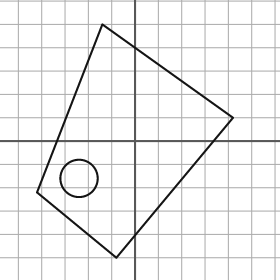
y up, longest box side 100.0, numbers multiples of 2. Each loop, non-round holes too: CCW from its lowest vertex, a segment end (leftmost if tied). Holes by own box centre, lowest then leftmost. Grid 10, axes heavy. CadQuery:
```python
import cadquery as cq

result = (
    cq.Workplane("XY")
    .moveTo(-8.0, -50.0)
    .lineTo(42.0, 10.0)
    .lineTo(-14.0, 50.0)
    .lineTo(-42.0, -22.0)
    .close()
    .moveTo(-24.0, -16.0)
    .circle(8.0)
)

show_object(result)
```